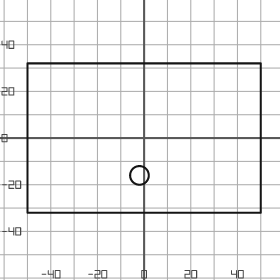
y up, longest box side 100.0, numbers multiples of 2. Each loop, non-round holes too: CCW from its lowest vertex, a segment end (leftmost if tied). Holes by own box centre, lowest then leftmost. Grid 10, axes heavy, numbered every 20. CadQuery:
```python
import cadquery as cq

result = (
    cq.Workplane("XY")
    .moveTo(-50.0, -32.0)
    .lineTo(50.0, -32.0)
    .lineTo(50.0, 32.0)
    .lineTo(-50.0, 32.0)
    .close()
    .moveTo(-2.0, -16.0)
    .circle(4.0)
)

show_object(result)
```